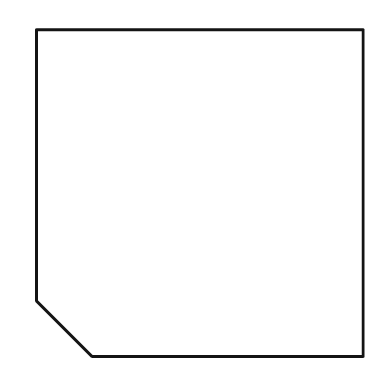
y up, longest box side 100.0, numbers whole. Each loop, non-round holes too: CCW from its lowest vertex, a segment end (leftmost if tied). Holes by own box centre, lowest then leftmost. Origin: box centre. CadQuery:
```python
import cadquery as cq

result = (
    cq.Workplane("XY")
    .moveTo(-33.0, -50.0)
    .lineTo(50.0, -50.0)
    .lineTo(50.0, 50.0)
    .lineTo(-50.0, 50.0)
    .lineTo(-50.0, -33.0)
    .close()
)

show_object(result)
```